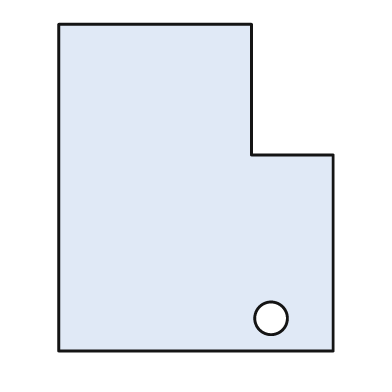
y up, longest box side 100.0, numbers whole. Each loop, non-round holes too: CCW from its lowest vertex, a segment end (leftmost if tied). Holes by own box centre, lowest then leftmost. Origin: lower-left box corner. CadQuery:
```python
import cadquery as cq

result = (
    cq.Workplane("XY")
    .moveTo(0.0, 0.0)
    .lineTo(84.0, 0.0)
    .lineTo(84.0, 60.0)
    .lineTo(59.0, 60.0)
    .lineTo(59.0, 100.0)
    .lineTo(0.0, 100.0)
    .close()
    .moveTo(65.0, 10.0)
    .circle(5.0)
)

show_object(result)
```